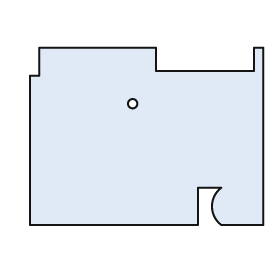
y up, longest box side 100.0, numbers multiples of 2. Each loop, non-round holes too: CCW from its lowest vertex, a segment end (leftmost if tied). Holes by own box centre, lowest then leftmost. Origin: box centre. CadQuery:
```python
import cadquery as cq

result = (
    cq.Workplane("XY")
    .moveTo(-50.0, -38.0)
    .lineTo(22.0, -38.0)
    .lineTo(22.0, -22.0)
    .lineTo(32.0, -22.0)
    .threePointArc((28.0, -30.0), (32.0, -38.0))
    .lineTo(50.0, -38.0)
    .lineTo(50.0, 38.0)
    .lineTo(46.0, 38.0)
    .lineTo(46.0, 28.0)
    .lineTo(4.0, 28.0)
    .lineTo(4.0, 38.0)
    .lineTo(-46.0, 38.0)
    .lineTo(-46.0, 26.0)
    .lineTo(-50.0, 26.0)
    .close()
    .moveTo(-6.0, 14.0)
    .circle(2.0)
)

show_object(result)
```